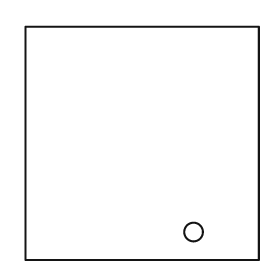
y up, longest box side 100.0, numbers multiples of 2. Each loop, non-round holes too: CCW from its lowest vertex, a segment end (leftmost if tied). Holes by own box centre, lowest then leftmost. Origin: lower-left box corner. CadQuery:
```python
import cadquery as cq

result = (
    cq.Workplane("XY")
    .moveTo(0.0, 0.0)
    .lineTo(100.0, 0.0)
    .lineTo(100.0, 100.0)
    .lineTo(0.0, 100.0)
    .close()
    .moveTo(72.0, 12.0)
    .circle(4.0)
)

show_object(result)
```